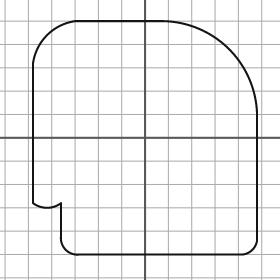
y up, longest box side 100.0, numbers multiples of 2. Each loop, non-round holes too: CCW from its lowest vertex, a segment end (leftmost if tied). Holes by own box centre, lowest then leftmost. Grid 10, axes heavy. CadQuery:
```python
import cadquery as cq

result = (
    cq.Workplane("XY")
    .moveTo(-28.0, -50.0)
    .lineTo(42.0, -50.0)
    .threePointArc((46.0, -48.0), (48.0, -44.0))
    .lineTo(48.0, 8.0)
    .threePointArc((36.0, 38.0), (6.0, 50.0))
    .lineTo(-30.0, 50.0)
    .threePointArc((-42.0, 44.0), (-48.0, 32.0))
    .lineTo(-48.0, -28.0)
    .threePointArc((-42.0, -30.0), (-36.0, -28.0))
    .lineTo(-36.0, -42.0)
    .threePointArc((-34.0, -48.0), (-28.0, -50.0))
    .close()
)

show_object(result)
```